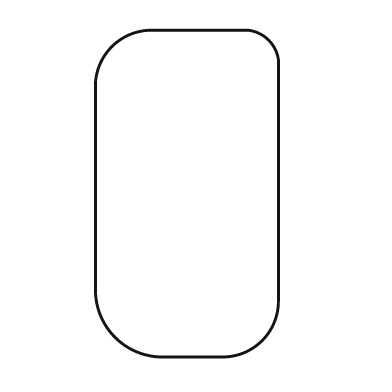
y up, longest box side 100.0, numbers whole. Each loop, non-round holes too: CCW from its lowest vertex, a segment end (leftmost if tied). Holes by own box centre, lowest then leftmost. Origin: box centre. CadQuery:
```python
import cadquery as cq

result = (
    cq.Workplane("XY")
    .moveTo(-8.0, -50.0)
    .lineTo(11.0, -50.0)
    .threePointArc((23.0, -45.0), (28.0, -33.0))
    .lineTo(28.0, 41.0)
    .threePointArc((25.0, 47.0), (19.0, 50.0))
    .lineTo(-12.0, 50.0)
    .threePointArc((-23.0, 45.0), (-28.0, 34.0))
    .lineTo(-28.0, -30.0)
    .threePointArc((-22.0, -44.0), (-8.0, -50.0))
    .close()
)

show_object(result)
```